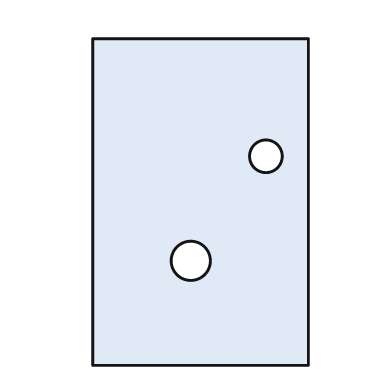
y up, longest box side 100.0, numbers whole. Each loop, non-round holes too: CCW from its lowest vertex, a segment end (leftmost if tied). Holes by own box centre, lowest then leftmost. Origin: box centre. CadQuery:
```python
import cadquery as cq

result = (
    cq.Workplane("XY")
    .moveTo(-33.0, -50.0)
    .lineTo(33.0, -50.0)
    .lineTo(33.0, 50.0)
    .lineTo(-33.0, 50.0)
    .close()
    .moveTo(-3.0, -18.0)
    .circle(6.0)
    .moveTo(20.0, 14.0)
    .circle(5.0)
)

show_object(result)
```